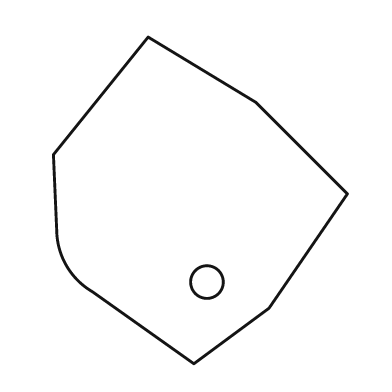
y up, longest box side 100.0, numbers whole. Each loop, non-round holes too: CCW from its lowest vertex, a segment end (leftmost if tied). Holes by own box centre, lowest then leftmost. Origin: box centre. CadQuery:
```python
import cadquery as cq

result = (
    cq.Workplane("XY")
    .moveTo(-2.0, -50.0)
    .lineTo(21.0, -33.0)
    .lineTo(45.0, 2.0)
    .lineTo(17.0, 30.0)
    .lineTo(-16.0, 50.0)
    .lineTo(-45.0, 14.0)
    .lineTo(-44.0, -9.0)
    .threePointArc((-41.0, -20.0), (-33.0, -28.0))
    .close()
    .moveTo(2.0, -25.0)
    .circle(5.0)
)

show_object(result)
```